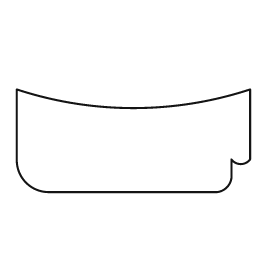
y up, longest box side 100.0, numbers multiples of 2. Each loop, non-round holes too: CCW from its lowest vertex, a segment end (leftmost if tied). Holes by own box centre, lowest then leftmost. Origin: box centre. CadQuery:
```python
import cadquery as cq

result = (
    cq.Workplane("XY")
    .moveTo(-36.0, -22.0)
    .lineTo(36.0, -22.0)
    .threePointArc((40.0, -20.0), (42.0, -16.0))
    .lineTo(42.0, -8.0)
    .threePointArc((46.0, -10.0), (50.0, -8.0))
    .lineTo(50.0, 22.0)
    .threePointArc((0.0, 14.0), (-50.0, 22.0))
    .lineTo(-50.0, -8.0)
    .threePointArc((-46.0, -18.0), (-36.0, -22.0))
    .close()
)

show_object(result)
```